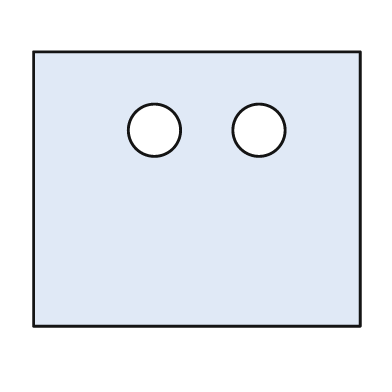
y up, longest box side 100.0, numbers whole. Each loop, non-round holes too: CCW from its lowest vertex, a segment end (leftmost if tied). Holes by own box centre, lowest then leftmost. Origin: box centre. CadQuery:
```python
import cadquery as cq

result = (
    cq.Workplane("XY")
    .moveTo(-50.0, -42.0)
    .lineTo(50.0, -42.0)
    .lineTo(50.0, 42.0)
    .lineTo(-50.0, 42.0)
    .close()
    .moveTo(-13.0, 18.0)
    .circle(8.0)
    .moveTo(19.0, 18.0)
    .circle(8.0)
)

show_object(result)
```